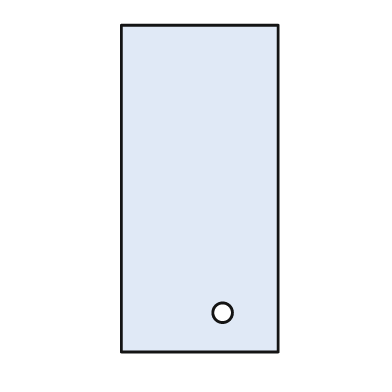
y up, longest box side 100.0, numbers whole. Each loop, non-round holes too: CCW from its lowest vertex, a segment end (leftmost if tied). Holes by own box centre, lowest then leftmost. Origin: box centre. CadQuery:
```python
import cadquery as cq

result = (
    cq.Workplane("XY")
    .moveTo(-24.0, -50.0)
    .lineTo(24.0, -50.0)
    .lineTo(24.0, 50.0)
    .lineTo(-24.0, 50.0)
    .close()
    .moveTo(7.0, -38.0)
    .circle(3.0)
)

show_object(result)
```